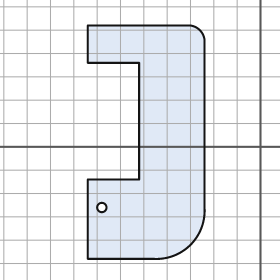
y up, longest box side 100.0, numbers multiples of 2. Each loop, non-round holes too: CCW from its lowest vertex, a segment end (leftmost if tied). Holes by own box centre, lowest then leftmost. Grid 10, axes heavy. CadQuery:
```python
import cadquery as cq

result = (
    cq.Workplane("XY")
    .moveTo(-74.0, -48.0)
    .lineTo(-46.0, -48.0)
    .threePointArc((-30.0, -42.0), (-24.0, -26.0))
    .lineTo(-24.0, 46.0)
    .threePointArc((-26.0, 50.0), (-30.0, 52.0))
    .lineTo(-74.0, 52.0)
    .lineTo(-74.0, 36.0)
    .lineTo(-52.0, 36.0)
    .lineTo(-52.0, -14.0)
    .lineTo(-74.0, -14.0)
    .close()
    .moveTo(-68.0, -26.0)
    .circle(2.0)
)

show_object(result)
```